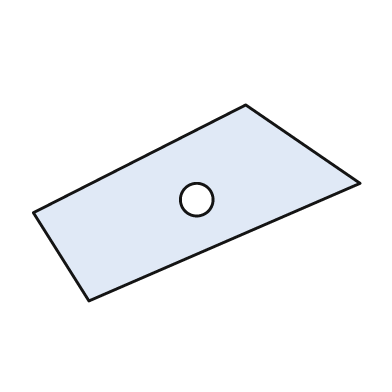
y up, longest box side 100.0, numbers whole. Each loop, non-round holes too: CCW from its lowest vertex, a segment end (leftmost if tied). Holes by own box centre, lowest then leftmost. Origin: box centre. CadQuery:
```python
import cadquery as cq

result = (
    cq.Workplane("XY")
    .moveTo(-33.0, -30.0)
    .lineTo(50.0, 6.0)
    .lineTo(15.0, 30.0)
    .lineTo(-50.0, -3.0)
    .close()
    .moveTo(0.0, 1.0)
    .circle(5.0)
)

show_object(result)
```